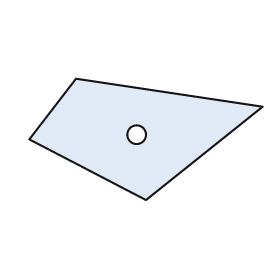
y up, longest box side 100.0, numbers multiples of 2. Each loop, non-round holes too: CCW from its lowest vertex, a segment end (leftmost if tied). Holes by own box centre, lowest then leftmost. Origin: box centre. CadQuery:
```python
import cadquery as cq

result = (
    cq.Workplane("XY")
    .moveTo(0.0, -26.0)
    .lineTo(50.0, 14.0)
    .lineTo(-30.0, 26.0)
    .lineTo(-50.0, 0.0)
    .close()
    .moveTo(-4.0, 2.0)
    .circle(4.0)
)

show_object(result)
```